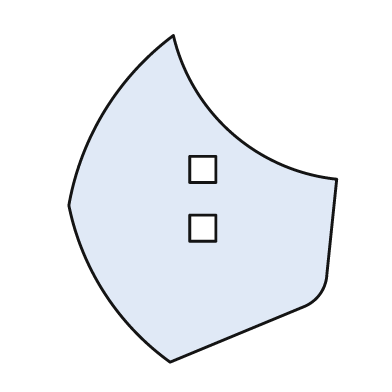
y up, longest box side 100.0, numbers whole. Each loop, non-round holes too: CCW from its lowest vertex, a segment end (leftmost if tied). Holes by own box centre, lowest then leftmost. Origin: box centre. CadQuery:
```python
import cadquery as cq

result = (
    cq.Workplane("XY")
    .moveTo(-10.0, -50.0)
    .lineTo(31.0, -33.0)
    .threePointArc((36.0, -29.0), (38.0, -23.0))
    .lineTo(41.0, 6.0)
    .threePointArc((9.0, 20.0), (-9.0, 50.0))
    .threePointArc((-30.0, 27.0), (-41.0, -2.0))
    .threePointArc((-30.0, -29.0), (-10.0, -50.0))
    .close()
    .moveTo(-4.0, -13.0)
    .lineTo(4.0, -13.0)
    .lineTo(4.0, -5.0)
    .lineTo(-4.0, -5.0)
    .close()
    .moveTo(-4.0, 5.0)
    .lineTo(4.0, 5.0)
    .lineTo(4.0, 13.0)
    .lineTo(-4.0, 13.0)
    .close()
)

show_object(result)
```